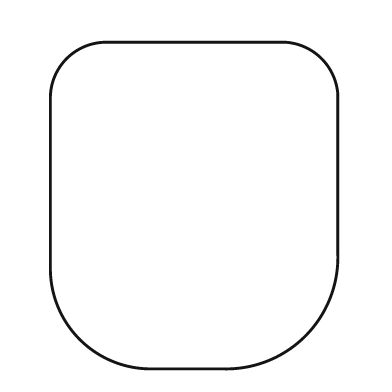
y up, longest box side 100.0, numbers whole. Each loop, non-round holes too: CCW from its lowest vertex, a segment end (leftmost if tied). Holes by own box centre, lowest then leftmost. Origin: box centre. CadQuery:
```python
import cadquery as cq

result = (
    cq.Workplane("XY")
    .moveTo(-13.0, -50.0)
    .lineTo(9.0, -50.0)
    .threePointArc((34.0, -40.0), (44.0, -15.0))
    .lineTo(44.0, 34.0)
    .threePointArc((39.0, 45.0), (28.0, 50.0))
    .lineTo(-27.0, 50.0)
    .threePointArc((-39.0, 45.0), (-44.0, 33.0))
    .lineTo(-44.0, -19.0)
    .threePointArc((-35.0, -41.0), (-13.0, -50.0))
    .close()
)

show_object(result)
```